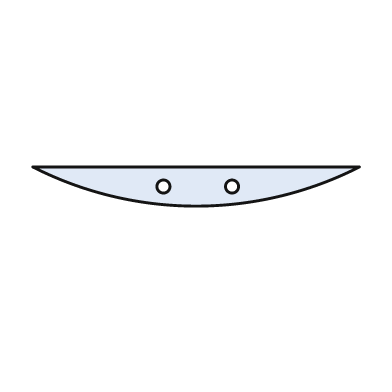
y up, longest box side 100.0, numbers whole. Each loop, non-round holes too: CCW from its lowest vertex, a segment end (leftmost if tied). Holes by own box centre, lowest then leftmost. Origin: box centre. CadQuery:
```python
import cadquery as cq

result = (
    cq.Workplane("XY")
    .moveTo(-50.0, 6.0)
    .threePointArc((0.0, -6.0), (50.0, 6.0))
    .close()
    .moveTo(-10.0, 0.0)
    .circle(2.0)
    .moveTo(11.0, 0.0)
    .circle(2.0)
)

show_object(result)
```